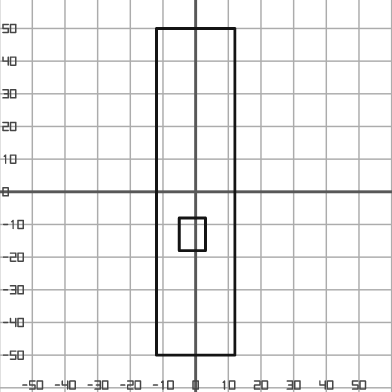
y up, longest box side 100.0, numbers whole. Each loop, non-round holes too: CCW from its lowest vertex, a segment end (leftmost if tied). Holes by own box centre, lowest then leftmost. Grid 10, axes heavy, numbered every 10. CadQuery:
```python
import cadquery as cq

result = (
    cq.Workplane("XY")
    .moveTo(-12.0, -50.0)
    .lineTo(12.0, -50.0)
    .lineTo(12.0, 50.0)
    .lineTo(-12.0, 50.0)
    .close()
    .moveTo(-5.0, -18.0)
    .lineTo(3.0, -18.0)
    .lineTo(3.0, -8.0)
    .lineTo(-5.0, -8.0)
    .close()
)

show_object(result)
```